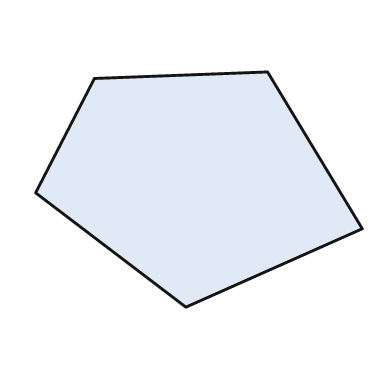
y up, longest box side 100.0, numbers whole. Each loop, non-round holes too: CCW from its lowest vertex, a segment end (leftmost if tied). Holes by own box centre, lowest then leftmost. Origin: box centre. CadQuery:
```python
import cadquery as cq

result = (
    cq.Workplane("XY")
    .moveTo(-4.0, -36.0)
    .lineTo(50.0, -12.0)
    .lineTo(21.0, 36.0)
    .lineTo(-32.0, 34.0)
    .lineTo(-50.0, -1.0)
    .close()
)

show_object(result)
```